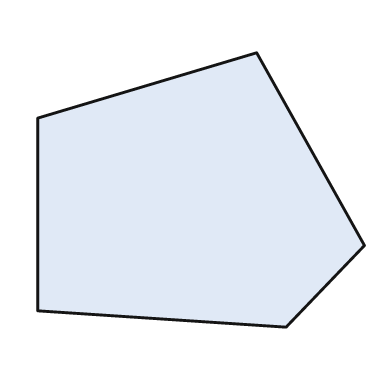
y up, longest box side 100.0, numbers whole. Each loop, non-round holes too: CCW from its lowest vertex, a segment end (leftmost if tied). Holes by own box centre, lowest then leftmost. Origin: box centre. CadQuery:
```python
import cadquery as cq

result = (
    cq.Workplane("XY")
    .moveTo(26.0, -42.0)
    .lineTo(50.0, -17.0)
    .lineTo(17.0, 42.0)
    .lineTo(-50.0, 22.0)
    .lineTo(-50.0, -37.0)
    .close()
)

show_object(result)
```